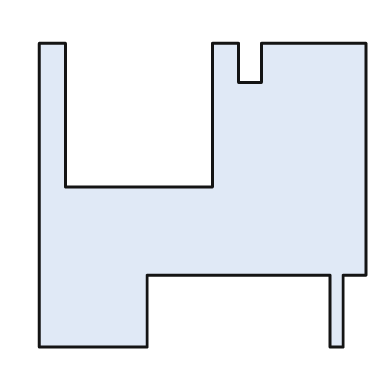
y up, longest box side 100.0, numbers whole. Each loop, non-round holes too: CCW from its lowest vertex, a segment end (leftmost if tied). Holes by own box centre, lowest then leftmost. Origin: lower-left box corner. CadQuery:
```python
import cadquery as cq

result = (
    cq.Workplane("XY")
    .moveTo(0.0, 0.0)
    .lineTo(33.0, 0.0)
    .lineTo(33.0, 22.0)
    .lineTo(89.0, 22.0)
    .lineTo(89.0, 0.0)
    .lineTo(93.0, 0.0)
    .lineTo(93.0, 22.0)
    .lineTo(100.0, 22.0)
    .lineTo(100.0, 93.0)
    .lineTo(68.0, 93.0)
    .lineTo(68.0, 81.0)
    .lineTo(61.0, 81.0)
    .lineTo(61.0, 93.0)
    .lineTo(53.0, 93.0)
    .lineTo(53.0, 49.0)
    .lineTo(8.0, 49.0)
    .lineTo(8.0, 93.0)
    .lineTo(0.0, 93.0)
    .close()
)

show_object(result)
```